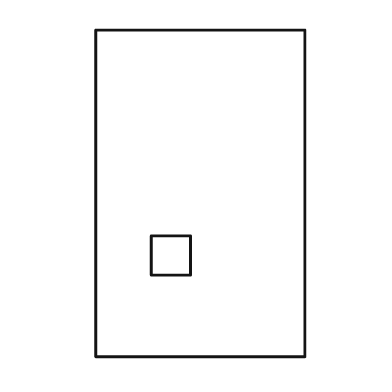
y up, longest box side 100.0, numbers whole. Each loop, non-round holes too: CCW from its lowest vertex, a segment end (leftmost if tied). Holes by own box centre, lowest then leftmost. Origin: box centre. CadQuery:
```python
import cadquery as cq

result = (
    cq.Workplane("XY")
    .moveTo(-32.0, -50.0)
    .lineTo(32.0, -50.0)
    .lineTo(32.0, 50.0)
    .lineTo(-32.0, 50.0)
    .close()
    .moveTo(-15.0, -25.0)
    .lineTo(-3.0, -25.0)
    .lineTo(-3.0, -13.0)
    .lineTo(-15.0, -13.0)
    .close()
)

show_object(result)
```